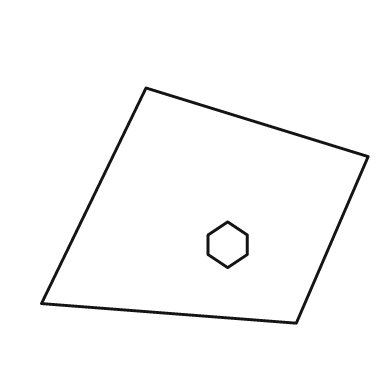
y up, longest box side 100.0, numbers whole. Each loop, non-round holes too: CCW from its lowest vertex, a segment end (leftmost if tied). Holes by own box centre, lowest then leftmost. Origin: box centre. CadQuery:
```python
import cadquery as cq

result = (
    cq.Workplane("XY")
    .moveTo(28.0, -36.0)
    .lineTo(50.0, 15.0)
    .lineTo(-18.0, 36.0)
    .lineTo(-50.0, -30.0)
    .close()
    .moveTo(7.0, -19.0)
    .lineTo(13.0, -15.0)
    .lineTo(13.0, -9.0)
    .lineTo(7.0, -5.0)
    .lineTo(1.0, -9.0)
    .lineTo(1.0, -15.0)
    .close()
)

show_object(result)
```